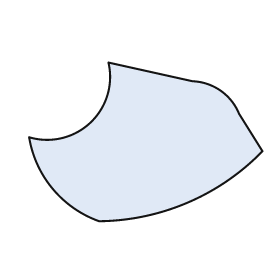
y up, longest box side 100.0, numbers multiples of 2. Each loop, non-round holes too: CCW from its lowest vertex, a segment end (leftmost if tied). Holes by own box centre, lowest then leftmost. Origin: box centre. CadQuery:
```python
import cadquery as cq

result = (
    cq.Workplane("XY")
    .moveTo(-20.0, -34.0)
    .threePointArc((18.0, -26.0), (50.0, -4.0))
    .lineTo(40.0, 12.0)
    .threePointArc((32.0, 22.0), (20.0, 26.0))
    .lineTo(-16.0, 34.0)
    .threePointArc((-24.0, 8.0), (-50.0, 2.0))
    .threePointArc((-40.0, -20.0), (-20.0, -34.0))
    .close()
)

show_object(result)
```